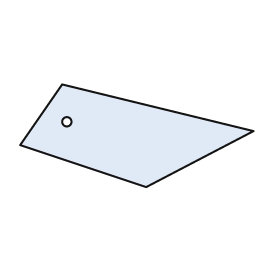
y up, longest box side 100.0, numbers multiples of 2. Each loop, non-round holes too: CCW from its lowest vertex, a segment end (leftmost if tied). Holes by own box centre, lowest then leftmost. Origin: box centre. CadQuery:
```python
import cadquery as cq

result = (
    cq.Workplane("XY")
    .moveTo(4.0, -22.0)
    .lineTo(50.0, 2.0)
    .lineTo(-32.0, 22.0)
    .lineTo(-50.0, -4.0)
    .close()
    .moveTo(-30.0, 6.0)
    .circle(2.0)
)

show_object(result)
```